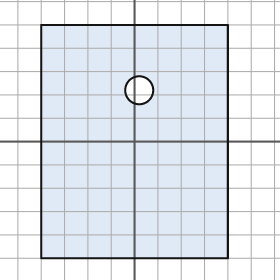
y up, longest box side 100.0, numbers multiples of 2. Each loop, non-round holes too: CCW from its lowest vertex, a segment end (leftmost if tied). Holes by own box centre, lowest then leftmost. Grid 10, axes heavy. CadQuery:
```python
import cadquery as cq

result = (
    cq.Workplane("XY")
    .moveTo(-40.0, -50.0)
    .lineTo(40.0, -50.0)
    .lineTo(40.0, 50.0)
    .lineTo(-40.0, 50.0)
    .close()
    .moveTo(2.0, 22.0)
    .circle(6.0)
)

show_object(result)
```